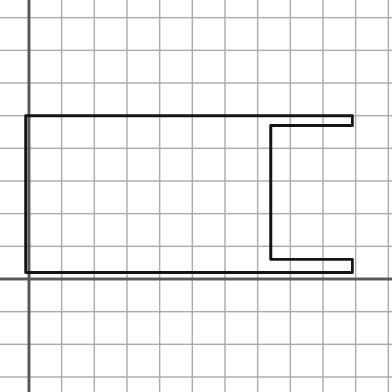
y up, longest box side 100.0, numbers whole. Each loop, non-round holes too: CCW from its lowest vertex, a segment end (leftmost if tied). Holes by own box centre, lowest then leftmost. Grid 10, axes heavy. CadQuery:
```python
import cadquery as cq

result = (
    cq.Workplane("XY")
    .moveTo(-1.0, 2.0)
    .lineTo(99.0, 2.0)
    .lineTo(99.0, 6.0)
    .lineTo(74.0, 6.0)
    .lineTo(74.0, 47.0)
    .lineTo(99.0, 47.0)
    .lineTo(99.0, 50.0)
    .lineTo(-1.0, 50.0)
    .close()
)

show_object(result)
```